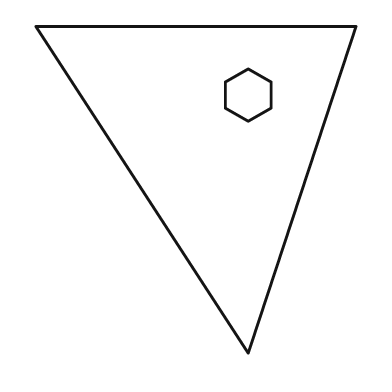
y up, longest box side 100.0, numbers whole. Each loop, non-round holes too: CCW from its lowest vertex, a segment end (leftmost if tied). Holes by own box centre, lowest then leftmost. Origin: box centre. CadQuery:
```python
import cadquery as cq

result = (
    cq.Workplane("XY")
    .moveTo(16.0, -50.0)
    .lineTo(49.0, 50.0)
    .lineTo(-49.0, 50.0)
    .close()
    .moveTo(16.0, 21.0)
    .lineTo(23.0, 25.0)
    .lineTo(23.0, 33.0)
    .lineTo(16.0, 37.0)
    .lineTo(9.0, 33.0)
    .lineTo(9.0, 25.0)
    .close()
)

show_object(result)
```